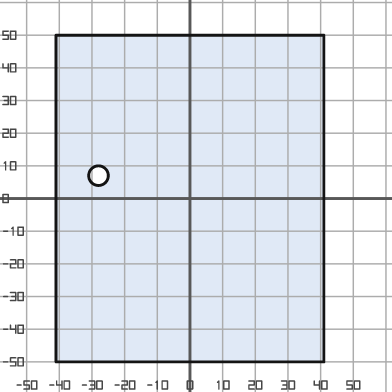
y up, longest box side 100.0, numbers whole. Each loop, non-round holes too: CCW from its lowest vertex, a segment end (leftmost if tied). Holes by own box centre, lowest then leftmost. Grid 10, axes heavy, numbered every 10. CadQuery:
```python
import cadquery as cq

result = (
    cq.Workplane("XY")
    .moveTo(-41.0, -50.0)
    .lineTo(41.0, -50.0)
    .lineTo(41.0, 50.0)
    .lineTo(-41.0, 50.0)
    .close()
    .moveTo(-28.0, 7.0)
    .circle(3.0)
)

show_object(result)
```